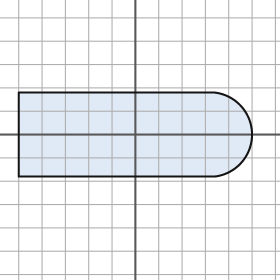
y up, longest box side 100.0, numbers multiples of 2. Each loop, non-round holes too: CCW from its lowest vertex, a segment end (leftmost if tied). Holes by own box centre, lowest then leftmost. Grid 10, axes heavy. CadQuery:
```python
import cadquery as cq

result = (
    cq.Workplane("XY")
    .moveTo(-50.0, -18.0)
    .lineTo(34.0, -18.0)
    .threePointArc((50.0, 0.0), (34.0, 18.0))
    .lineTo(-50.0, 18.0)
    .close()
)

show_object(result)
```